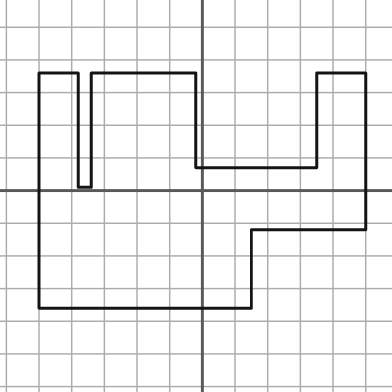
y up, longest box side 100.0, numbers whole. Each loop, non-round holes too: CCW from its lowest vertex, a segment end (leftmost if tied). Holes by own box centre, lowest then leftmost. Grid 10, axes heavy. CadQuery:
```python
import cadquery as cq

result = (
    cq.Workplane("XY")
    .moveTo(-50.0, -36.0)
    .lineTo(15.0, -36.0)
    .lineTo(15.0, -12.0)
    .lineTo(50.0, -12.0)
    .lineTo(50.0, 36.0)
    .lineTo(35.0, 36.0)
    .lineTo(35.0, 7.0)
    .lineTo(-2.0, 7.0)
    .lineTo(-2.0, 36.0)
    .lineTo(-34.0, 36.0)
    .lineTo(-34.0, 1.0)
    .lineTo(-38.0, 1.0)
    .lineTo(-38.0, 36.0)
    .lineTo(-50.0, 36.0)
    .close()
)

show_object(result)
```